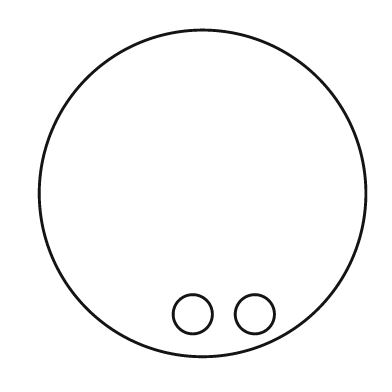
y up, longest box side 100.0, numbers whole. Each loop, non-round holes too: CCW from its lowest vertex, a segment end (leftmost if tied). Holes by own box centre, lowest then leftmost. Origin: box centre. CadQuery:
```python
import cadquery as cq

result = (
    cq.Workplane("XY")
    .moveTo(0.0, 0.0)
    .circle(50.0)
    .moveTo(-3.0, -37.0)
    .circle(6.0)
    .moveTo(16.0, -37.0)
    .circle(6.0)
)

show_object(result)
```